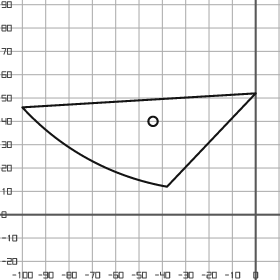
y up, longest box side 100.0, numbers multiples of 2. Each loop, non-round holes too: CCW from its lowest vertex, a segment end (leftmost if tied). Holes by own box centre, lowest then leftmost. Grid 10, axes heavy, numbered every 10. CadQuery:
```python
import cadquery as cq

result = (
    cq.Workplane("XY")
    .moveTo(-38.0, 12.0)
    .lineTo(0.0, 52.0)
    .lineTo(-100.0, 46.0)
    .threePointArc((-72.0, 24.0), (-38.0, 12.0))
    .close()
    .moveTo(-44.0, 40.0)
    .circle(2.0)
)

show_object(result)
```